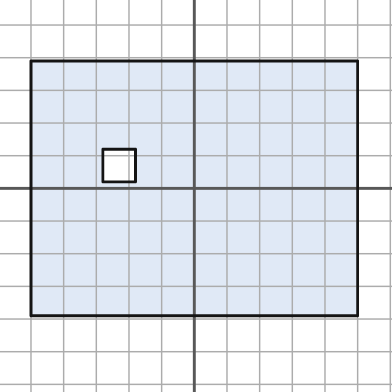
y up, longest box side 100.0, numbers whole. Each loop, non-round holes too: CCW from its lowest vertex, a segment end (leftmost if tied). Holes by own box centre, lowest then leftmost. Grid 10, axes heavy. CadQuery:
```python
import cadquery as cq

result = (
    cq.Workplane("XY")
    .moveTo(-50.0, -39.0)
    .lineTo(50.0, -39.0)
    .lineTo(50.0, 39.0)
    .lineTo(-50.0, 39.0)
    .close()
    .moveTo(-28.0, 2.0)
    .lineTo(-18.0, 2.0)
    .lineTo(-18.0, 12.0)
    .lineTo(-28.0, 12.0)
    .close()
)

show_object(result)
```